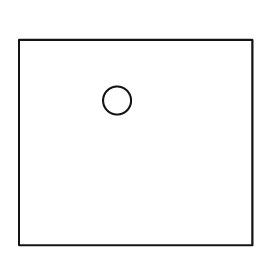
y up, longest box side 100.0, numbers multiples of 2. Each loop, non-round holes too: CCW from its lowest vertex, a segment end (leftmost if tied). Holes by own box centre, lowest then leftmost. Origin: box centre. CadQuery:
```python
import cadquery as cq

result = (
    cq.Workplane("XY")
    .moveTo(-50.0, -44.0)
    .lineTo(50.0, -44.0)
    .lineTo(50.0, 44.0)
    .lineTo(-50.0, 44.0)
    .close()
    .moveTo(-8.0, 18.0)
    .circle(6.0)
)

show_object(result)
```